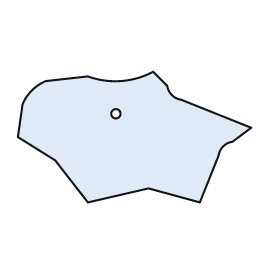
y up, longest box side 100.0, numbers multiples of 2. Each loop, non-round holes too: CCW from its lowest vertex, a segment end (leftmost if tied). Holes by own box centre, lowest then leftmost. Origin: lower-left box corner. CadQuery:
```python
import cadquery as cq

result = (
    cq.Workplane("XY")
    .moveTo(30.0, 0.0)
    .lineTo(56.0, 6.0)
    .lineTo(78.0, 0.0)
    .lineTo(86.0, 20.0)
    .threePointArc((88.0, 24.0), (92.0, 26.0))
    .lineTo(100.0, 32.0)
    .lineTo(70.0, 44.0)
    .threePointArc((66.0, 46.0), (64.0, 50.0))
    .lineTo(58.0, 56.0)
    .threePointArc((44.0, 52.0), (30.0, 54.0))
    .lineTo(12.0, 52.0)
    .threePointArc((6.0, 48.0), (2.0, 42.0))
    .lineTo(0.0, 28.0)
    .lineTo(16.0, 18.0)
    .close()
    .moveTo(42.0, 38.0)
    .circle(2.0)
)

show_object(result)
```